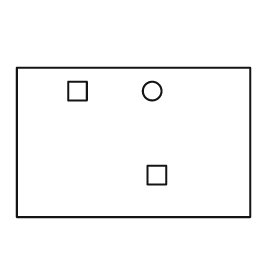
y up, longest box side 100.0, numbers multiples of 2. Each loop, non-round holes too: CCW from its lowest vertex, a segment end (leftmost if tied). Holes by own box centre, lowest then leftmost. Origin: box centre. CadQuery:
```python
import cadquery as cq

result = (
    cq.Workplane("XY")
    .moveTo(-50.0, -32.0)
    .lineTo(50.0, -32.0)
    .lineTo(50.0, 32.0)
    .lineTo(-50.0, 32.0)
    .close()
    .moveTo(6.0, -18.0)
    .lineTo(14.0, -18.0)
    .lineTo(14.0, -10.0)
    .lineTo(6.0, -10.0)
    .close()
    .moveTo(-28.0, 18.0)
    .lineTo(-20.0, 18.0)
    .lineTo(-20.0, 26.0)
    .lineTo(-28.0, 26.0)
    .close()
    .moveTo(8.0, 22.0)
    .circle(4.0)
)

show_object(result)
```